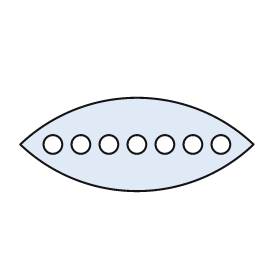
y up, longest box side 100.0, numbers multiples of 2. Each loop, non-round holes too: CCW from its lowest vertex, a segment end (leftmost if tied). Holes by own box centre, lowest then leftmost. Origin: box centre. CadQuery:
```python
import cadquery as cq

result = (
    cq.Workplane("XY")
    .moveTo(-50.0, 0.0)
    .threePointArc((0.0, -20.0), (50.0, 0.0))
    .threePointArc((0.0, 20.0), (-50.0, 0.0))
    .close()
    .moveTo(-36.0, 0.0)
    .circle(4.0)
    .moveTo(-24.0, 0.0)
    .circle(4.0)
    .moveTo(-12.0, 0.0)
    .circle(4.0)
    .moveTo(0.0, 0.0)
    .circle(4.0)
    .moveTo(12.0, 0.0)
    .circle(4.0)
    .moveTo(24.0, 0.0)
    .circle(4.0)
    .moveTo(36.0, 0.0)
    .circle(4.0)
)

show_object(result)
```